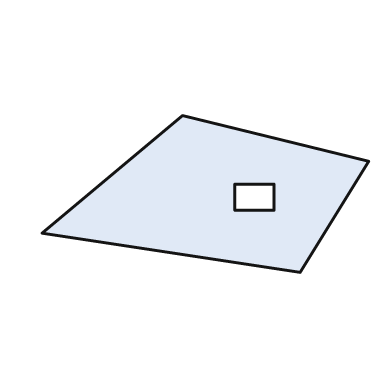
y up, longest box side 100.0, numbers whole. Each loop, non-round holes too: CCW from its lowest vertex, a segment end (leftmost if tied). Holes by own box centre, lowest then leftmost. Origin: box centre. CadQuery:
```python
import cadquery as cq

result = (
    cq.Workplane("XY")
    .moveTo(29.0, -24.0)
    .lineTo(50.0, 10.0)
    .lineTo(-7.0, 24.0)
    .lineTo(-50.0, -12.0)
    .close()
    .moveTo(9.0, -5.0)
    .lineTo(21.0, -5.0)
    .lineTo(21.0, 3.0)
    .lineTo(9.0, 3.0)
    .close()
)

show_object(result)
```